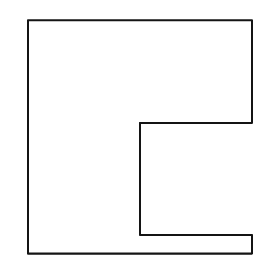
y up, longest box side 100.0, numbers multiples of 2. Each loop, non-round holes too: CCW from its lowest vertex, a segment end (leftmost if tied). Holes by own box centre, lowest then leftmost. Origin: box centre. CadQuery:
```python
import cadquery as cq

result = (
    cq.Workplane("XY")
    .moveTo(-48.0, -50.0)
    .lineTo(48.0, -50.0)
    .lineTo(48.0, -42.0)
    .lineTo(0.0, -42.0)
    .lineTo(0.0, 6.0)
    .lineTo(48.0, 6.0)
    .lineTo(48.0, 50.0)
    .lineTo(-48.0, 50.0)
    .close()
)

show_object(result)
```